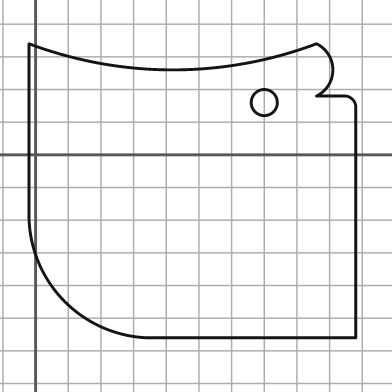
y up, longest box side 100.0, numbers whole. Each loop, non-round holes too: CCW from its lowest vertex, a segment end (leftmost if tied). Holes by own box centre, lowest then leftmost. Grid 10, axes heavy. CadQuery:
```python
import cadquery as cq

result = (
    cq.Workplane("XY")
    .moveTo(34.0, -56.0)
    .lineTo(98.0, -56.0)
    .lineTo(98.0, 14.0)
    .threePointArc((97.0, 17.0), (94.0, 18.0))
    .lineTo(86.0, 18.0)
    .threePointArc((91.0, 26.0), (86.0, 34.0))
    .threePointArc((42.0, 26.0), (-2.0, 34.0))
    .lineTo(-2.0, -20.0)
    .threePointArc((9.0, -45.0), (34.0, -56.0))
    .close()
    .moveTo(70.0, 16.0)
    .circle(4.0)
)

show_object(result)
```